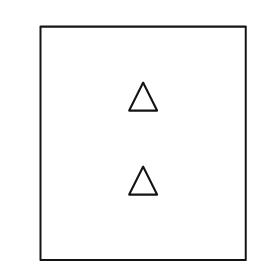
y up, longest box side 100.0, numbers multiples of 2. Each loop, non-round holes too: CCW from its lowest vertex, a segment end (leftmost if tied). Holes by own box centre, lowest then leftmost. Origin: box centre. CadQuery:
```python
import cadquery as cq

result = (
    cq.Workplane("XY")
    .moveTo(-44.0, -50.0)
    .lineTo(44.0, -50.0)
    .lineTo(44.0, 50.0)
    .lineTo(-44.0, 50.0)
    .close()
    .moveTo(-6.0, -22.0)
    .lineTo(6.0, -22.0)
    .lineTo(0.0, -10.0)
    .close()
    .moveTo(-6.0, 14.0)
    .lineTo(6.0, 14.0)
    .lineTo(0.0, 26.0)
    .close()
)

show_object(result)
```